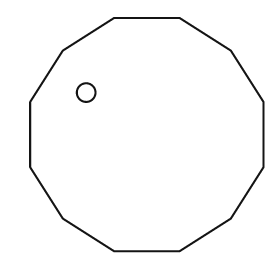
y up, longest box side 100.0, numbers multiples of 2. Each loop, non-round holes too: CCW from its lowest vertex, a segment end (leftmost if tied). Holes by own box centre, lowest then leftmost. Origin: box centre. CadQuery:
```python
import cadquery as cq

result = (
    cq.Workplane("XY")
    .moveTo(-14.0, -50.0)
    .lineTo(14.0, -50.0)
    .lineTo(36.0, -36.0)
    .lineTo(50.0, -14.0)
    .lineTo(50.0, 14.0)
    .lineTo(36.0, 36.0)
    .lineTo(14.0, 50.0)
    .lineTo(-14.0, 50.0)
    .lineTo(-36.0, 36.0)
    .lineTo(-50.0, 14.0)
    .lineTo(-50.0, -14.0)
    .lineTo(-36.0, -36.0)
    .close()
    .moveTo(-26.0, 18.0)
    .circle(4.0)
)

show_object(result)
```